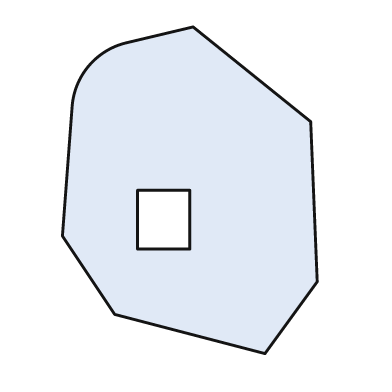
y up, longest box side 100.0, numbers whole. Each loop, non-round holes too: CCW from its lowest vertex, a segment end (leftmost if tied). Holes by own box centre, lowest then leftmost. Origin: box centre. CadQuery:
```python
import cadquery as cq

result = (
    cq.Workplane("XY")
    .moveTo(23.0, -50.0)
    .lineTo(39.0, -28.0)
    .lineTo(37.0, 21.0)
    .lineTo(1.0, 50.0)
    .lineTo(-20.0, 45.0)
    .threePointArc((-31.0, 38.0), (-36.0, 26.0))
    .lineTo(-39.0, -14.0)
    .lineTo(-23.0, -38.0)
    .close()
    .moveTo(-16.0, -18.0)
    .lineTo(0.0, -18.0)
    .lineTo(0.0, 0.0)
    .lineTo(-16.0, 0.0)
    .close()
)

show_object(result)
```